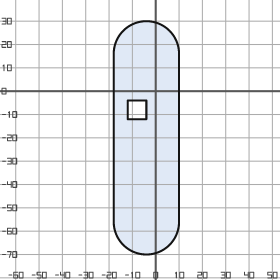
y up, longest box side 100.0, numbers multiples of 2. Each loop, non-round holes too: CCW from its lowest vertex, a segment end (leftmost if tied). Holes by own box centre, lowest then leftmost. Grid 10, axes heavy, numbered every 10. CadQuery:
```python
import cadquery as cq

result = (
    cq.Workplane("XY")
    .moveTo(-18.0, -56.0)
    .threePointArc((-4.0, -70.0), (10.0, -56.0))
    .lineTo(10.0, 16.0)
    .threePointArc((-4.0, 30.0), (-18.0, 16.0))
    .close()
    .moveTo(-12.0, -12.0)
    .lineTo(-4.0, -12.0)
    .lineTo(-4.0, -4.0)
    .lineTo(-12.0, -4.0)
    .close()
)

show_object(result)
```